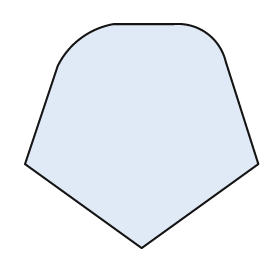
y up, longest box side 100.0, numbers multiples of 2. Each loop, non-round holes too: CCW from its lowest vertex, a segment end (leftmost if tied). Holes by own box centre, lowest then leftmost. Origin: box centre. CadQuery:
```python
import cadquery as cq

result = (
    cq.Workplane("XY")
    .moveTo(0.0, -48.0)
    .lineTo(50.0, -12.0)
    .lineTo(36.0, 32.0)
    .threePointArc((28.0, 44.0), (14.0, 48.0))
    .lineTo(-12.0, 48.0)
    .threePointArc((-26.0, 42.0), (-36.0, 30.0))
    .lineTo(-50.0, -12.0)
    .close()
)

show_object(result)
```